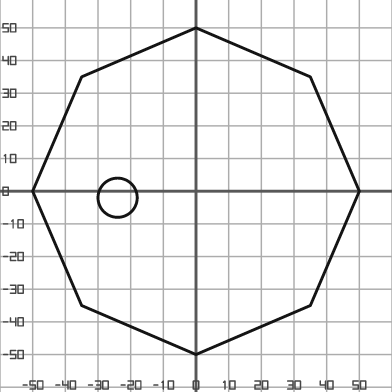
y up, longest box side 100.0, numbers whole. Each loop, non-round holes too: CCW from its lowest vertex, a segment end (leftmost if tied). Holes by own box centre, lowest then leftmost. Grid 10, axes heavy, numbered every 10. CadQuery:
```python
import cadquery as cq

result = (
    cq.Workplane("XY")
    .moveTo(0.0, -50.0)
    .lineTo(35.0, -35.0)
    .lineTo(50.0, 0.0)
    .lineTo(35.0, 35.0)
    .lineTo(0.0, 50.0)
    .lineTo(-35.0, 35.0)
    .lineTo(-50.0, 0.0)
    .lineTo(-35.0, -35.0)
    .close()
    .moveTo(-24.0, -2.0)
    .circle(6.0)
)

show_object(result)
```